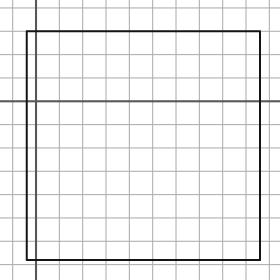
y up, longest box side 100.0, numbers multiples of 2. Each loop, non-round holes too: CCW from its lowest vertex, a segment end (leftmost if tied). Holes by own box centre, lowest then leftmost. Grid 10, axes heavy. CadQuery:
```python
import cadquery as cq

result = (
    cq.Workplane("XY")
    .moveTo(-4.0, -68.0)
    .lineTo(96.0, -68.0)
    .lineTo(96.0, 30.0)
    .lineTo(-4.0, 30.0)
    .close()
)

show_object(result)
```